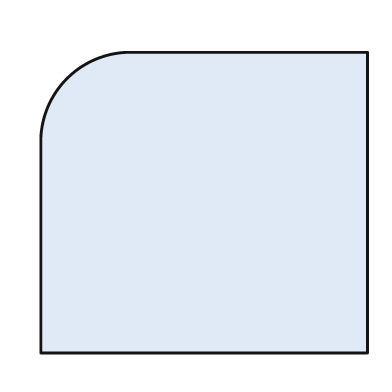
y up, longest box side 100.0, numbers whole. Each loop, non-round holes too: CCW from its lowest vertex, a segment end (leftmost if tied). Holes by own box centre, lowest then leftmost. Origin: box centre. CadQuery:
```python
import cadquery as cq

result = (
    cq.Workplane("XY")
    .moveTo(-50.0, -46.0)
    .lineTo(50.0, -46.0)
    .lineTo(50.0, 46.0)
    .lineTo(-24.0, 46.0)
    .threePointArc((-42.0, 38.0), (-50.0, 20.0))
    .close()
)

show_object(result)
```